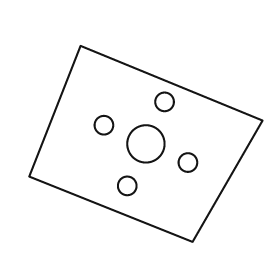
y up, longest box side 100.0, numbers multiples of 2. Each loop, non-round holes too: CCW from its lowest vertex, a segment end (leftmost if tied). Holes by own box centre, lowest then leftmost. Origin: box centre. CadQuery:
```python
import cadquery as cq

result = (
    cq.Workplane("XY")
    .moveTo(20.0, -42.0)
    .lineTo(50.0, 10.0)
    .lineTo(-28.0, 42.0)
    .lineTo(-50.0, -14.0)
    .close()
    .moveTo(-8.0, -18.0)
    .circle(4.0)
    .moveTo(18.0, -8.0)
    .circle(4.0)
    .moveTo(0.0, 0.0)
    .circle(8.0)
    .moveTo(-18.0, 8.0)
    .circle(4.0)
    .moveTo(8.0, 18.0)
    .circle(4.0)
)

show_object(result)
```